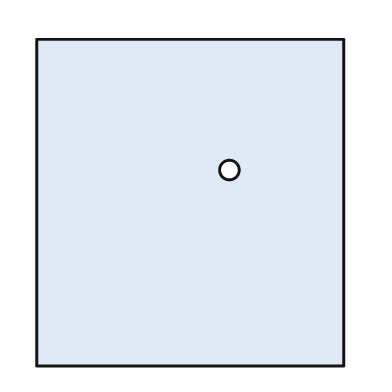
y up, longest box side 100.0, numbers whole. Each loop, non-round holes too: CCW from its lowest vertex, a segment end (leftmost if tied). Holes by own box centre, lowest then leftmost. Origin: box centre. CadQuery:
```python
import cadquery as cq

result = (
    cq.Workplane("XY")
    .moveTo(-47.0, -50.0)
    .lineTo(47.0, -50.0)
    .lineTo(47.0, 50.0)
    .lineTo(-47.0, 50.0)
    .close()
    .moveTo(12.0, 10.0)
    .circle(3.0)
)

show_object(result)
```